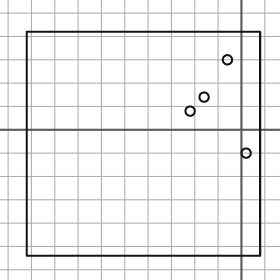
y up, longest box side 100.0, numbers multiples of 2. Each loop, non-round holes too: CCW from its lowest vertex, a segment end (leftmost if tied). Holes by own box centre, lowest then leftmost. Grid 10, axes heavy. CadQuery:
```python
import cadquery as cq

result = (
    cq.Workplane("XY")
    .moveTo(-92.0, -54.0)
    .lineTo(8.0, -54.0)
    .lineTo(8.0, 42.0)
    .lineTo(-92.0, 42.0)
    .close()
    .moveTo(2.0, -10.0)
    .circle(2.0)
    .moveTo(-22.0, 8.0)
    .circle(2.0)
    .moveTo(-16.0, 14.0)
    .circle(2.0)
    .moveTo(-6.0, 30.0)
    .circle(2.0)
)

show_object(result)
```